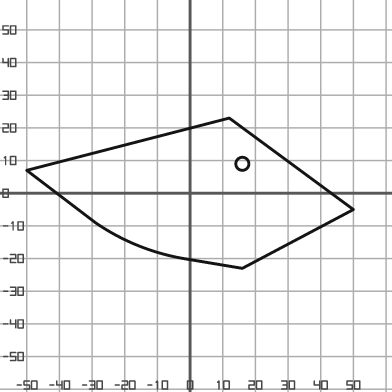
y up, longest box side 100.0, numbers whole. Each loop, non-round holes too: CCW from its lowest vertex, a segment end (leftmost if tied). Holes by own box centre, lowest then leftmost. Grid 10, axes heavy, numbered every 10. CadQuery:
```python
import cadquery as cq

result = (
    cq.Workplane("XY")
    .moveTo(16.0, -23.0)
    .lineTo(50.0, -5.0)
    .lineTo(12.0, 23.0)
    .lineTo(-50.0, 7.0)
    .lineTo(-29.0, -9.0)
    .threePointArc((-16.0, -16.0), (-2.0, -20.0))
    .close()
    .moveTo(16.0, 9.0)
    .circle(2.0)
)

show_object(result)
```